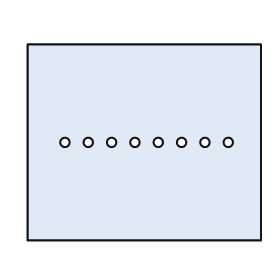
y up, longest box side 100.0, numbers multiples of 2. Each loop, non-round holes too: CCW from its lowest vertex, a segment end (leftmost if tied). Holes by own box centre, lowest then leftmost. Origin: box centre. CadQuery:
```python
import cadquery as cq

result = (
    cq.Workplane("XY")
    .moveTo(-50.0, -42.0)
    .lineTo(50.0, -42.0)
    .lineTo(50.0, 42.0)
    .lineTo(-50.0, 42.0)
    .close()
    .moveTo(-34.0, 0.0)
    .circle(2.0)
    .moveTo(-24.0, 0.0)
    .circle(2.0)
    .moveTo(-14.0, 0.0)
    .circle(2.0)
    .moveTo(-4.0, 0.0)
    .circle(2.0)
    .moveTo(6.0, 0.0)
    .circle(2.0)
    .moveTo(16.0, 0.0)
    .circle(2.0)
    .moveTo(26.0, 0.0)
    .circle(2.0)
    .moveTo(36.0, 0.0)
    .circle(2.0)
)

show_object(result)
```